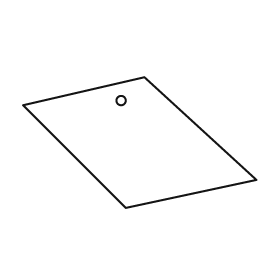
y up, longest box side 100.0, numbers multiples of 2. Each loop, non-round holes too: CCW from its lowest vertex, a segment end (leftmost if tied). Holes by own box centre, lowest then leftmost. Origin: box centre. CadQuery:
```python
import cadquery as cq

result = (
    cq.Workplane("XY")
    .moveTo(-6.0, -28.0)
    .lineTo(50.0, -16.0)
    .lineTo(2.0, 28.0)
    .lineTo(-50.0, 16.0)
    .close()
    .moveTo(-8.0, 18.0)
    .circle(2.0)
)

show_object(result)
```